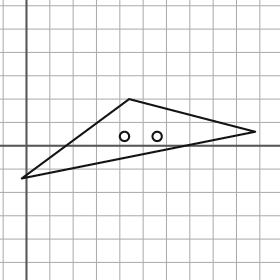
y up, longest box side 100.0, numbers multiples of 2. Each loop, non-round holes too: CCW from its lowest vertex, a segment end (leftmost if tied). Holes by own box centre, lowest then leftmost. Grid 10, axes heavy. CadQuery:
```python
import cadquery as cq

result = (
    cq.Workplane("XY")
    .moveTo(-2.0, -14.0)
    .lineTo(98.0, 6.0)
    .lineTo(44.0, 20.0)
    .close()
    .moveTo(42.0, 4.0)
    .circle(2.0)
    .moveTo(56.0, 4.0)
    .circle(2.0)
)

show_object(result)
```